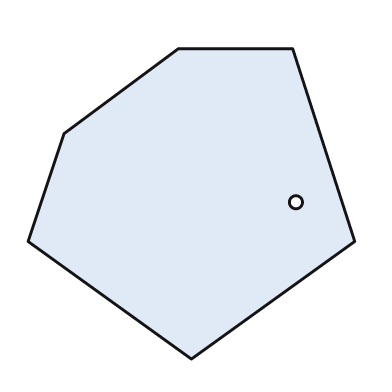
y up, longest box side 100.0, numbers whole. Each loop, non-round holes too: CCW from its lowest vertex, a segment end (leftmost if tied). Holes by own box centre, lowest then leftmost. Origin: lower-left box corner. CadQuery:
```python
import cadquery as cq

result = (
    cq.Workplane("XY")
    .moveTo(50.0, 0.0)
    .lineTo(100.0, 36.0)
    .lineTo(81.0, 95.0)
    .lineTo(46.0, 95.0)
    .lineTo(11.0, 69.0)
    .lineTo(0.0, 36.0)
    .close()
    .moveTo(82.0, 48.0)
    .circle(2.0)
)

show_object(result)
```